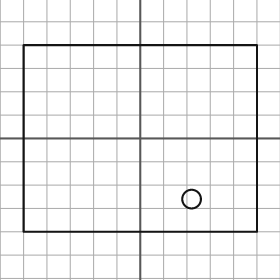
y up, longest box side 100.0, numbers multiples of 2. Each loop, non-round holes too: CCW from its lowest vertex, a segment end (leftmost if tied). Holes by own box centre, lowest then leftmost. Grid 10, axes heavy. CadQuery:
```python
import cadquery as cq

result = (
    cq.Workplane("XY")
    .moveTo(-50.0, -40.0)
    .lineTo(50.0, -40.0)
    .lineTo(50.0, 40.0)
    .lineTo(-50.0, 40.0)
    .close()
    .moveTo(22.0, -26.0)
    .circle(4.0)
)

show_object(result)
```